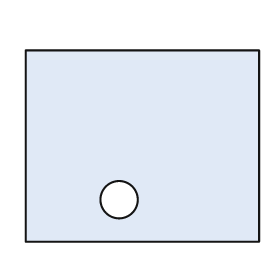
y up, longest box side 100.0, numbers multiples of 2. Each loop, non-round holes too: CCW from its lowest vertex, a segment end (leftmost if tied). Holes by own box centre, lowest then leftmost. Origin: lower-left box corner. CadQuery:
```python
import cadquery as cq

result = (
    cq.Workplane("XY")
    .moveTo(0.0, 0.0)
    .lineTo(100.0, 0.0)
    .lineTo(100.0, 82.0)
    .lineTo(0.0, 82.0)
    .close()
    .moveTo(40.0, 18.0)
    .circle(8.0)
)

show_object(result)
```